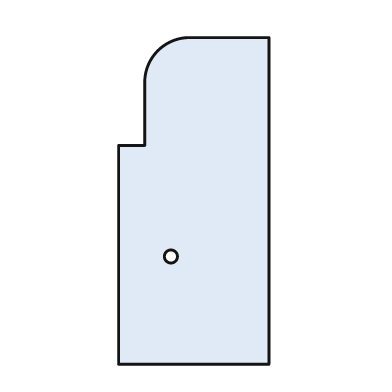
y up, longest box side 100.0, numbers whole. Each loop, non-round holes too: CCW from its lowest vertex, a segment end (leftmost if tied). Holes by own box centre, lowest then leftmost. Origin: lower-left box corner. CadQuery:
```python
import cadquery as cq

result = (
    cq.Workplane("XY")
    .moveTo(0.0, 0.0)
    .lineTo(46.0, 0.0)
    .lineTo(46.0, 100.0)
    .lineTo(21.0, 100.0)
    .threePointArc((12.0, 96.0), (8.0, 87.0))
    .lineTo(8.0, 67.0)
    .lineTo(0.0, 67.0)
    .close()
    .moveTo(16.0, 33.0)
    .circle(2.0)
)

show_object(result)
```